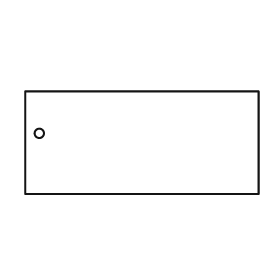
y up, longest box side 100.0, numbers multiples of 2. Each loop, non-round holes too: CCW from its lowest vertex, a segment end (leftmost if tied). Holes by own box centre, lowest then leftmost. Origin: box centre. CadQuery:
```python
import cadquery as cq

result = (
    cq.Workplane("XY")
    .moveTo(-50.0, -22.0)
    .lineTo(50.0, -22.0)
    .lineTo(50.0, 22.0)
    .lineTo(-50.0, 22.0)
    .close()
    .moveTo(-44.0, 4.0)
    .circle(2.0)
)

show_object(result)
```